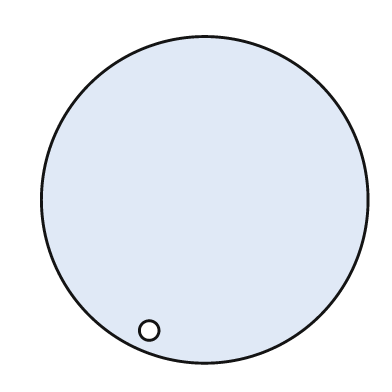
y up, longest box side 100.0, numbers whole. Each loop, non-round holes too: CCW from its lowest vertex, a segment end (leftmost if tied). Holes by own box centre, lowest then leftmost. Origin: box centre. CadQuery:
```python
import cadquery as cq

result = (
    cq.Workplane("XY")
    .moveTo(0.0, 0.0)
    .circle(50.0)
    .moveTo(-17.0, -40.0)
    .circle(3.0)
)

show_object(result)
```